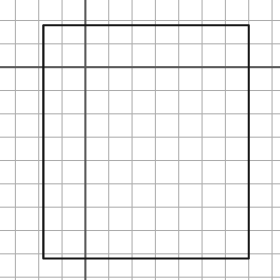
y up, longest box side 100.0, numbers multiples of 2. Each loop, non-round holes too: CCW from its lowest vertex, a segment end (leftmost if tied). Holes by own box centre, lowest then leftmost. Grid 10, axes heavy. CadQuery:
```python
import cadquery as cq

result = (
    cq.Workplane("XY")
    .moveTo(-18.0, -82.0)
    .lineTo(70.0, -82.0)
    .lineTo(70.0, 18.0)
    .lineTo(-18.0, 18.0)
    .close()
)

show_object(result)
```